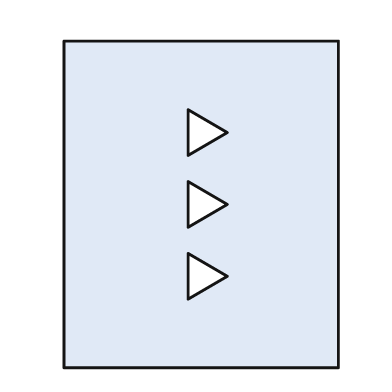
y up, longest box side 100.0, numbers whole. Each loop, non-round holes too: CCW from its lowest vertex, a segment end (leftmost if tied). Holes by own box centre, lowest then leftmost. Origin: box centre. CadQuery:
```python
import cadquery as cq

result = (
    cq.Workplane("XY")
    .moveTo(-42.0, -50.0)
    .lineTo(42.0, -50.0)
    .lineTo(42.0, 50.0)
    .lineTo(-42.0, 50.0)
    .close()
    .moveTo(-4.0, -29.0)
    .lineTo(8.0, -22.0)
    .lineTo(-4.0, -15.0)
    .close()
    .moveTo(-4.0, -7.0)
    .lineTo(8.0, 0.0)
    .lineTo(-4.0, 7.0)
    .close()
    .moveTo(-4.0, 15.0)
    .lineTo(8.0, 22.0)
    .lineTo(-4.0, 29.0)
    .close()
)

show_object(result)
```